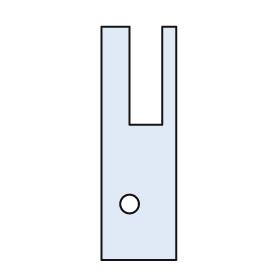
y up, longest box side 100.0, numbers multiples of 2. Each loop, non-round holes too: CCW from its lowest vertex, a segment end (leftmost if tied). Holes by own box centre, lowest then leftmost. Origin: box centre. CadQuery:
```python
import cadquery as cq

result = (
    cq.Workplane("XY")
    .moveTo(-16.0, -50.0)
    .lineTo(16.0, -50.0)
    .lineTo(16.0, 50.0)
    .lineTo(10.0, 50.0)
    .lineTo(10.0, 8.0)
    .lineTo(-4.0, 8.0)
    .lineTo(-4.0, 50.0)
    .lineTo(-16.0, 50.0)
    .close()
    .moveTo(-4.0, -26.0)
    .circle(4.0)
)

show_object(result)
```